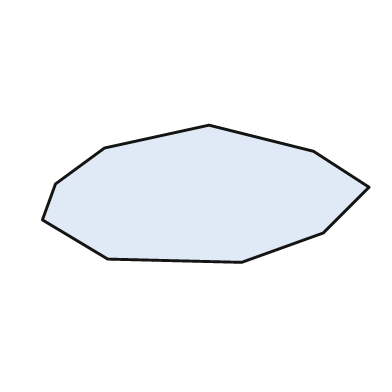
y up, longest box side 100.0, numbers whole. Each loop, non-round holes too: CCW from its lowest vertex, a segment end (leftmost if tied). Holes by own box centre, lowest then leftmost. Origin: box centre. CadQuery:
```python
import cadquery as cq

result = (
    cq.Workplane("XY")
    .moveTo(11.0, -21.0)
    .lineTo(36.0, -12.0)
    .lineTo(50.0, 2.0)
    .lineTo(33.0, 13.0)
    .lineTo(1.0, 21.0)
    .lineTo(-31.0, 14.0)
    .lineTo(-46.0, 3.0)
    .lineTo(-50.0, -8.0)
    .lineTo(-30.0, -20.0)
    .close()
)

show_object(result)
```